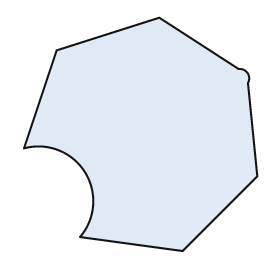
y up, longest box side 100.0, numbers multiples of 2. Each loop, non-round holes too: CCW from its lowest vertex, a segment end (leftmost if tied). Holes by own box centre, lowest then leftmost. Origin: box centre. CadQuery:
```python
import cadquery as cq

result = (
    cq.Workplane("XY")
    .moveTo(18.0, -50.0)
    .lineTo(50.0, -18.0)
    .lineTo(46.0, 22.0)
    .threePointArc((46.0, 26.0), (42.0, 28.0))
    .lineTo(8.0, 50.0)
    .lineTo(-36.0, 36.0)
    .lineTo(-50.0, -6.0)
    .threePointArc((-24.0, -16.0), (-26.0, -44.0))
    .close()
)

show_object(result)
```